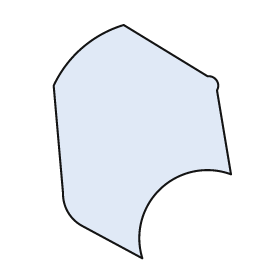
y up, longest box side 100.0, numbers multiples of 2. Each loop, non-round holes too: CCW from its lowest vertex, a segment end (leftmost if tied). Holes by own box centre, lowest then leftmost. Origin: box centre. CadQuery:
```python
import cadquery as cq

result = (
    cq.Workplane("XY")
    .moveTo(0.0, -50.0)
    .threePointArc((8.0, -20.0), (38.0, -14.0))
    .lineTo(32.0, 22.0)
    .threePointArc((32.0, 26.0), (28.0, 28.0))
    .lineTo(-8.0, 50.0)
    .threePointArc((-26.0, 40.0), (-38.0, 24.0))
    .lineTo(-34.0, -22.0)
    .threePointArc((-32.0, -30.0), (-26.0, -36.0))
    .close()
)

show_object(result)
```